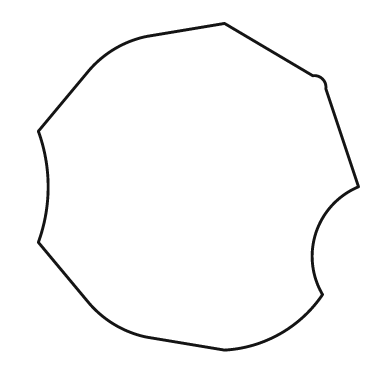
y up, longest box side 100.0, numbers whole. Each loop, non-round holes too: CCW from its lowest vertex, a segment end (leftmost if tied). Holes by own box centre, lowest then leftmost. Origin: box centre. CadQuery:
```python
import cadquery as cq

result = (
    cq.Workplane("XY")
    .moveTo(8.0, -50.0)
    .threePointArc((25.0, -45.0), (38.0, -33.0))
    .threePointArc((36.0, -14.0), (49.0, 0.0))
    .lineTo(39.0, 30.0)
    .threePointArc((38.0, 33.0), (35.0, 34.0))
    .lineTo(8.0, 50.0)
    .lineTo(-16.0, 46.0)
    .threePointArc((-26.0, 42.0), (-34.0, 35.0))
    .lineTo(-49.0, 17.0)
    .threePointArc((-46.0, 0.0), (-49.0, -17.0))
    .lineTo(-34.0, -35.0)
    .threePointArc((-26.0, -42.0), (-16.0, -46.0))
    .close()
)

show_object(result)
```